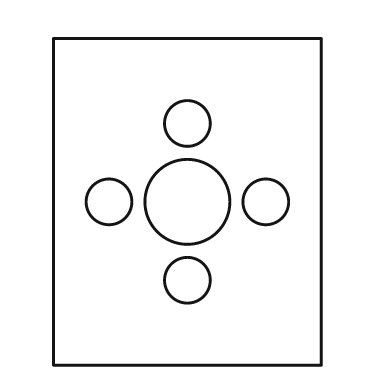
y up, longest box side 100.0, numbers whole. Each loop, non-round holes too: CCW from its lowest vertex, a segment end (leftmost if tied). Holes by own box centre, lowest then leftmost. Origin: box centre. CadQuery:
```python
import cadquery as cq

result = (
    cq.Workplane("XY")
    .moveTo(-41.0, -50.0)
    .lineTo(41.0, -50.0)
    .lineTo(41.0, 50.0)
    .lineTo(-41.0, 50.0)
    .close()
    .moveTo(0.0, -24.0)
    .circle(7.0)
    .moveTo(-24.0, 0.0)
    .circle(7.0)
    .moveTo(0.0, 0.0)
    .circle(13.0)
    .moveTo(24.0, 0.0)
    .circle(7.0)
    .moveTo(0.0, 24.0)
    .circle(7.0)
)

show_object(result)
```